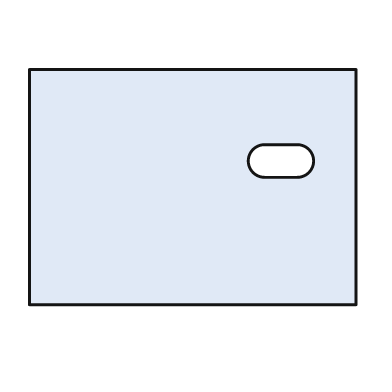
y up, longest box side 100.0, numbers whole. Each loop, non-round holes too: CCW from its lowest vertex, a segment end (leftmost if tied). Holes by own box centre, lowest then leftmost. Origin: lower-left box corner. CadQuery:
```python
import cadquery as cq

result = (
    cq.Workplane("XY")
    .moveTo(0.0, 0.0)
    .lineTo(100.0, 0.0)
    .lineTo(100.0, 72.0)
    .lineTo(0.0, 72.0)
    .close()
    .moveTo(72.0, 39.0)
    .lineTo(82.0, 39.0)
    .threePointArc((87.0, 44.0), (82.0, 49.0))
    .lineTo(72.0, 49.0)
    .threePointArc((67.0, 44.0), (72.0, 39.0))
    .close()
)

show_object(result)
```